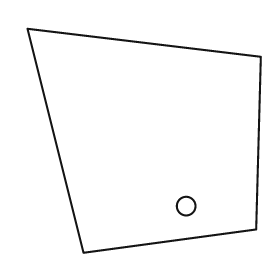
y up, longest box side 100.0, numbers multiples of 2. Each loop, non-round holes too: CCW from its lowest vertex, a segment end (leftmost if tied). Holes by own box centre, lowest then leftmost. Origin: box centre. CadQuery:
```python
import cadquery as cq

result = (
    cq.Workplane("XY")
    .moveTo(-26.0, -48.0)
    .lineTo(48.0, -38.0)
    .lineTo(50.0, 36.0)
    .lineTo(-50.0, 48.0)
    .close()
    .moveTo(18.0, -28.0)
    .circle(4.0)
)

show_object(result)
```